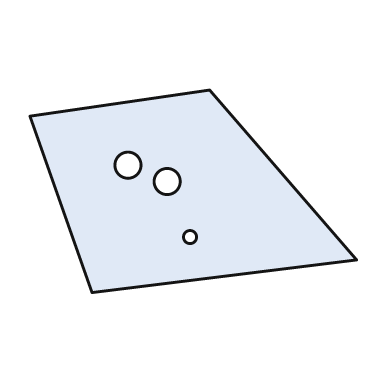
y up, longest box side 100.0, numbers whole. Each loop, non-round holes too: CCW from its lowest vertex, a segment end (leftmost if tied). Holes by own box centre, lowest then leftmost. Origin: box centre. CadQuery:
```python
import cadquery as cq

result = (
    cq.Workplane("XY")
    .moveTo(-31.0, -31.0)
    .lineTo(50.0, -21.0)
    .lineTo(5.0, 31.0)
    .lineTo(-50.0, 23.0)
    .close()
    .moveTo(-1.0, -14.0)
    .circle(2.0)
    .moveTo(-8.0, 3.0)
    .circle(4.0)
    .moveTo(-20.0, 8.0)
    .circle(4.0)
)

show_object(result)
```